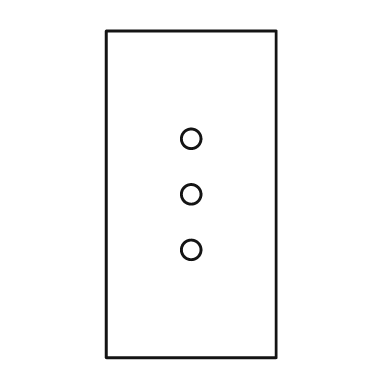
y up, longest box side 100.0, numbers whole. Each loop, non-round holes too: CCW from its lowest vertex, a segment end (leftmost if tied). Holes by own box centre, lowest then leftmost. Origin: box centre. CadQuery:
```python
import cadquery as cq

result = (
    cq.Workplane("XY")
    .moveTo(-26.0, -50.0)
    .lineTo(26.0, -50.0)
    .lineTo(26.0, 50.0)
    .lineTo(-26.0, 50.0)
    .close()
    .moveTo(0.0, -17.0)
    .circle(3.0)
    .moveTo(0.0, 0.0)
    .circle(3.0)
    .moveTo(0.0, 17.0)
    .circle(3.0)
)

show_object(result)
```